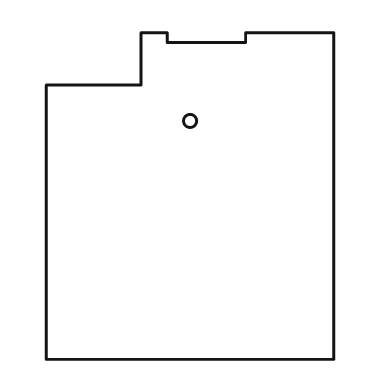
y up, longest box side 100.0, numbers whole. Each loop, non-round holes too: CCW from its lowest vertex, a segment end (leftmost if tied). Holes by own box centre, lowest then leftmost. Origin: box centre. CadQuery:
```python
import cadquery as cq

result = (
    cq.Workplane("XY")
    .moveTo(-44.0, -50.0)
    .lineTo(44.0, -50.0)
    .lineTo(44.0, 50.0)
    .lineTo(17.0, 50.0)
    .lineTo(17.0, 47.0)
    .lineTo(-7.0, 47.0)
    .lineTo(-7.0, 50.0)
    .lineTo(-15.0, 50.0)
    .lineTo(-15.0, 34.0)
    .lineTo(-44.0, 34.0)
    .close()
    .moveTo(0.0, 23.0)
    .circle(2.0)
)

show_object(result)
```